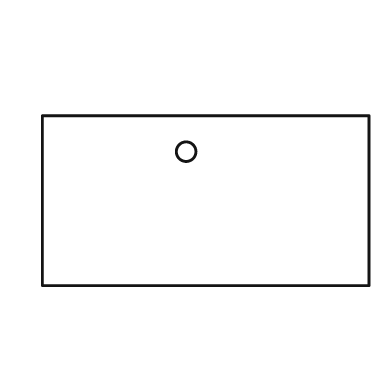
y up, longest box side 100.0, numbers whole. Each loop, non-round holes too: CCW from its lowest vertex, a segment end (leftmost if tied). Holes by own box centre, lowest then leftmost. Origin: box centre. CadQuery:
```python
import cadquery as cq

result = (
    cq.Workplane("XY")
    .moveTo(-50.0, -26.0)
    .lineTo(50.0, -26.0)
    .lineTo(50.0, 26.0)
    .lineTo(-50.0, 26.0)
    .close()
    .moveTo(-6.0, 15.0)
    .circle(3.0)
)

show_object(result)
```